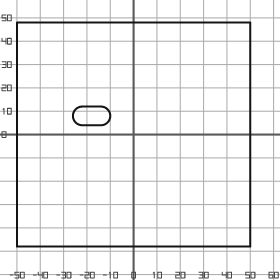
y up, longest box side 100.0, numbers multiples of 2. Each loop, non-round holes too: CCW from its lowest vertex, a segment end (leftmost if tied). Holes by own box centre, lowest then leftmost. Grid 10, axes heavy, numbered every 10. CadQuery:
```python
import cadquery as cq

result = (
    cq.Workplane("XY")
    .moveTo(-50.0, -48.0)
    .lineTo(50.0, -48.0)
    .lineTo(50.0, 48.0)
    .lineTo(-50.0, 48.0)
    .close()
    .moveTo(-22.0, 4.0)
    .lineTo(-14.0, 4.0)
    .threePointArc((-10.0, 8.0), (-14.0, 12.0))
    .lineTo(-22.0, 12.0)
    .threePointArc((-26.0, 8.0), (-22.0, 4.0))
    .close()
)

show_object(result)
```